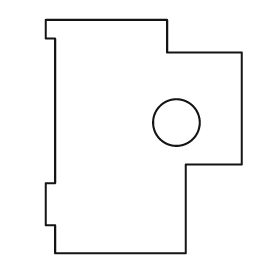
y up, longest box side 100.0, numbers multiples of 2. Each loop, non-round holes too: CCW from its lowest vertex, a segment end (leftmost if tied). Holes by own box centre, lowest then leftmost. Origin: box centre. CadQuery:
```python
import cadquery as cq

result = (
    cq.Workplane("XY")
    .moveTo(-38.0, -50.0)
    .lineTo(18.0, -50.0)
    .lineTo(18.0, -12.0)
    .lineTo(42.0, -12.0)
    .lineTo(42.0, 36.0)
    .lineTo(10.0, 36.0)
    .lineTo(10.0, 50.0)
    .lineTo(-42.0, 50.0)
    .lineTo(-42.0, 42.0)
    .lineTo(-38.0, 42.0)
    .lineTo(-38.0, -20.0)
    .lineTo(-42.0, -20.0)
    .lineTo(-42.0, -38.0)
    .lineTo(-38.0, -38.0)
    .close()
    .moveTo(14.0, 6.0)
    .circle(10.0)
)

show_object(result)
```